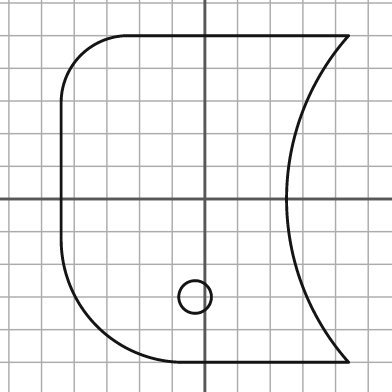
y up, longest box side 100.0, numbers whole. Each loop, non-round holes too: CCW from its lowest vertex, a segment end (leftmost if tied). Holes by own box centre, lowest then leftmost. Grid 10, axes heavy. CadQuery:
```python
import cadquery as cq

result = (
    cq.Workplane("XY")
    .moveTo(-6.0, -50.0)
    .lineTo(44.0, -50.0)
    .threePointArc((25.0, 0.0), (44.0, 50.0))
    .lineTo(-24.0, 50.0)
    .threePointArc((-38.0, 44.0), (-44.0, 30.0))
    .lineTo(-44.0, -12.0)
    .threePointArc((-33.0, -39.0), (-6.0, -50.0))
    .close()
    .moveTo(-3.0, -30.0)
    .circle(5.0)
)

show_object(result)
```